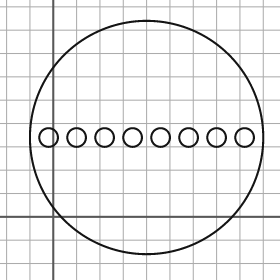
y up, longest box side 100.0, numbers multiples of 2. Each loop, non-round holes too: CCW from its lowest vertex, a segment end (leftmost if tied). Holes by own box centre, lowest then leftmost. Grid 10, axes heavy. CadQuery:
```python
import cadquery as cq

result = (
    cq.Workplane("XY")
    .moveTo(40.0, 34.0)
    .circle(50.0)
    .moveTo(-2.0, 34.0)
    .circle(4.0)
    .moveTo(10.0, 34.0)
    .circle(4.0)
    .moveTo(22.0, 34.0)
    .circle(4.0)
    .moveTo(34.0, 34.0)
    .circle(4.0)
    .moveTo(46.0, 34.0)
    .circle(4.0)
    .moveTo(58.0, 34.0)
    .circle(4.0)
    .moveTo(70.0, 34.0)
    .circle(4.0)
    .moveTo(82.0, 34.0)
    .circle(4.0)
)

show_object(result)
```